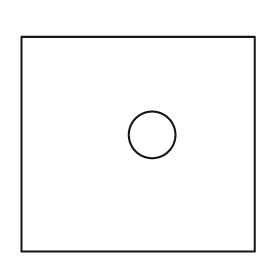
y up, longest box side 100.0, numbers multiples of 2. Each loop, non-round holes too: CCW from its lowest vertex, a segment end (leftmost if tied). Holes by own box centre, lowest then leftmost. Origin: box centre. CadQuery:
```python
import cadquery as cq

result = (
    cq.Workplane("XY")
    .moveTo(-50.0, -46.0)
    .lineTo(50.0, -46.0)
    .lineTo(50.0, 46.0)
    .lineTo(-50.0, 46.0)
    .close()
    .moveTo(6.0, 4.0)
    .circle(10.0)
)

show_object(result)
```